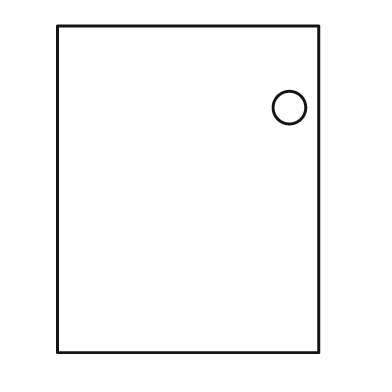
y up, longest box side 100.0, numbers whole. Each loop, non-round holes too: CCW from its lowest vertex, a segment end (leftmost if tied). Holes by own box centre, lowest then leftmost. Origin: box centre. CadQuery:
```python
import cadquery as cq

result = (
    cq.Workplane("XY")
    .moveTo(-40.0, -50.0)
    .lineTo(40.0, -50.0)
    .lineTo(40.0, 50.0)
    .lineTo(-40.0, 50.0)
    .close()
    .moveTo(31.0, 25.0)
    .circle(5.0)
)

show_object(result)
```